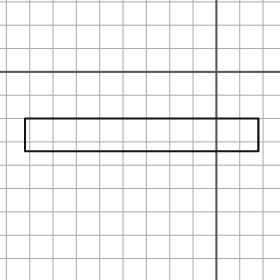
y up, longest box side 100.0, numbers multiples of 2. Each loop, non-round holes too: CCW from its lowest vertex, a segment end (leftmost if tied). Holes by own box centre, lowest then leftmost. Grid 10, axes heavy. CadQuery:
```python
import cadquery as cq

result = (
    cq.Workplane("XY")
    .moveTo(-82.0, -34.0)
    .lineTo(18.0, -34.0)
    .lineTo(18.0, -20.0)
    .lineTo(-82.0, -20.0)
    .close()
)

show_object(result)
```